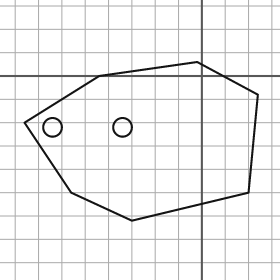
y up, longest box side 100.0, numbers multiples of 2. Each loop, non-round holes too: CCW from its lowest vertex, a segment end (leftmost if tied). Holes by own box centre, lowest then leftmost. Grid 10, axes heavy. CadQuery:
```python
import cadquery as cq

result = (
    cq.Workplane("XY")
    .moveTo(-30.0, -62.0)
    .lineTo(20.0, -50.0)
    .lineTo(24.0, -8.0)
    .lineTo(-2.0, 6.0)
    .lineTo(-44.0, 0.0)
    .lineTo(-76.0, -20.0)
    .lineTo(-56.0, -50.0)
    .close()
    .moveTo(-64.0, -22.0)
    .circle(4.0)
    .moveTo(-34.0, -22.0)
    .circle(4.0)
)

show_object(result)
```